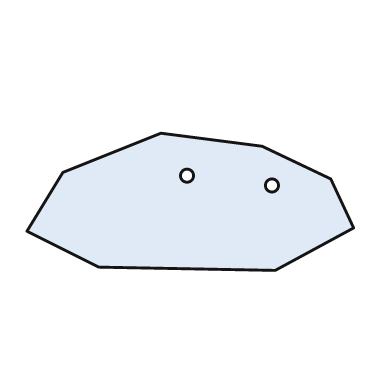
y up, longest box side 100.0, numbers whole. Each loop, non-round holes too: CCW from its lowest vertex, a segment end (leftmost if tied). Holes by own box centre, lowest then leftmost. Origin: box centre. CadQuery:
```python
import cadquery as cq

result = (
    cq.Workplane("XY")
    .moveTo(26.0, -21.0)
    .lineTo(50.0, -8.0)
    .lineTo(43.0, 7.0)
    .lineTo(22.0, 17.0)
    .lineTo(-9.0, 21.0)
    .lineTo(-39.0, 9.0)
    .lineTo(-50.0, -9.0)
    .lineTo(-28.0, -20.0)
    .close()
    .moveTo(25.0, 5.0)
    .circle(2.0)
    .moveTo(-1.0, 8.0)
    .circle(2.0)
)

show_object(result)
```